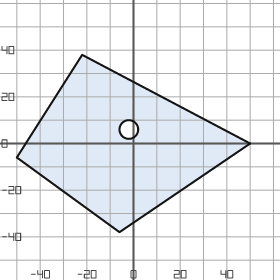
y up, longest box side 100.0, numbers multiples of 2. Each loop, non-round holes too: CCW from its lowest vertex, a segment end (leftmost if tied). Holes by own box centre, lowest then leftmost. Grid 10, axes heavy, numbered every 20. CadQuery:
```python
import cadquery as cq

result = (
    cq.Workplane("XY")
    .moveTo(-6.0, -38.0)
    .lineTo(50.0, 0.0)
    .lineTo(-22.0, 38.0)
    .lineTo(-50.0, -6.0)
    .close()
    .moveTo(-2.0, 6.0)
    .circle(4.0)
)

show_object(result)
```